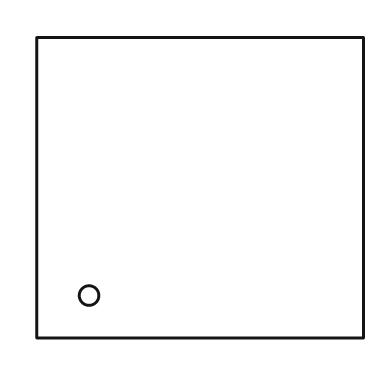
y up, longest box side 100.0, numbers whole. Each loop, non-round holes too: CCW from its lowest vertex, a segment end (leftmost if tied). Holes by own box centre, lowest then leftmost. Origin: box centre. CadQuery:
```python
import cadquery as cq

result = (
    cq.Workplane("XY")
    .moveTo(-50.0, -46.0)
    .lineTo(50.0, -46.0)
    .lineTo(50.0, 46.0)
    .lineTo(-50.0, 46.0)
    .close()
    .moveTo(-34.0, -33.0)
    .circle(3.0)
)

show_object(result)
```